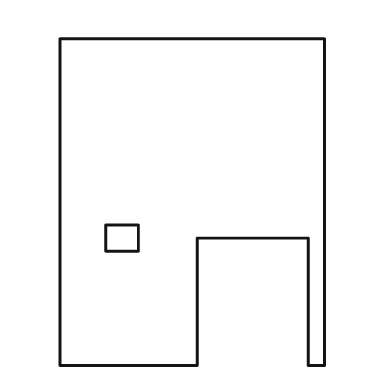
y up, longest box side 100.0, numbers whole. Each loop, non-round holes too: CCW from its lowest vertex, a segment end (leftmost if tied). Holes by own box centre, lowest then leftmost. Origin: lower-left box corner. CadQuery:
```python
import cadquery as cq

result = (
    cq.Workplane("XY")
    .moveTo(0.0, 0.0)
    .lineTo(42.0, 0.0)
    .lineTo(42.0, 39.0)
    .lineTo(76.0, 39.0)
    .lineTo(76.0, 0.0)
    .lineTo(81.0, 0.0)
    .lineTo(81.0, 100.0)
    .lineTo(0.0, 100.0)
    .close()
    .moveTo(14.0, 35.0)
    .lineTo(24.0, 35.0)
    .lineTo(24.0, 43.0)
    .lineTo(14.0, 43.0)
    .close()
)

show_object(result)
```